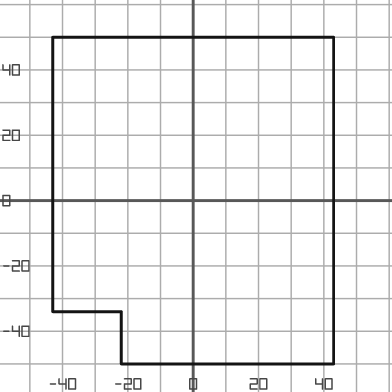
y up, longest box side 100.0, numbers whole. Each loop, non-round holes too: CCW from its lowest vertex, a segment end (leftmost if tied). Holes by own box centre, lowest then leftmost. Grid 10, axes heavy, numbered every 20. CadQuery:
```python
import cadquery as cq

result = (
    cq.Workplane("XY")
    .moveTo(-22.0, -50.0)
    .lineTo(43.0, -50.0)
    .lineTo(43.0, 50.0)
    .lineTo(-43.0, 50.0)
    .lineTo(-43.0, -34.0)
    .lineTo(-22.0, -34.0)
    .close()
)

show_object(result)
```